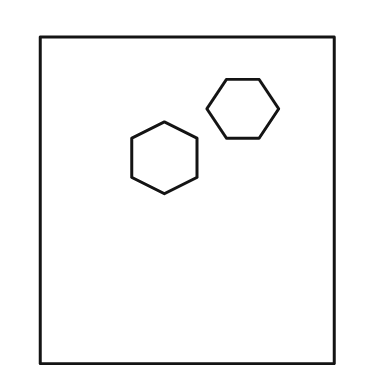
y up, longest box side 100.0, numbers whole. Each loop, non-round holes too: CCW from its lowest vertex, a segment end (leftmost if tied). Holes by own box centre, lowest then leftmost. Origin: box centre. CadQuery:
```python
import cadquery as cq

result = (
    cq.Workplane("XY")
    .moveTo(-45.0, -50.0)
    .lineTo(45.0, -50.0)
    .lineTo(45.0, 50.0)
    .lineTo(-45.0, 50.0)
    .close()
    .moveTo(-7.0, 2.0)
    .lineTo(3.0, 7.0)
    .lineTo(3.0, 19.0)
    .lineTo(-7.0, 24.0)
    .lineTo(-17.0, 19.0)
    .lineTo(-17.0, 7.0)
    .close()
    .moveTo(12.0, 19.0)
    .lineTo(22.0, 19.0)
    .lineTo(28.0, 28.0)
    .lineTo(22.0, 37.0)
    .lineTo(12.0, 37.0)
    .lineTo(6.0, 28.0)
    .close()
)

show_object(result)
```